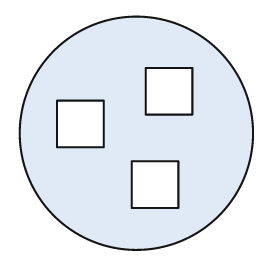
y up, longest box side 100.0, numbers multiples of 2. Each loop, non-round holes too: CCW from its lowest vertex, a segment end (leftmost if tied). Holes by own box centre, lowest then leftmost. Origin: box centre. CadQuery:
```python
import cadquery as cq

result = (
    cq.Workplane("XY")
    .moveTo(0.0, 0.0)
    .circle(50.0)
    .moveTo(-2.0, -32.0)
    .lineTo(18.0, -32.0)
    .lineTo(18.0, -12.0)
    .lineTo(-2.0, -12.0)
    .close()
    .moveTo(-34.0, -6.0)
    .lineTo(-14.0, -6.0)
    .lineTo(-14.0, 14.0)
    .lineTo(-34.0, 14.0)
    .close()
    .moveTo(4.0, 8.0)
    .lineTo(24.0, 8.0)
    .lineTo(24.0, 28.0)
    .lineTo(4.0, 28.0)
    .close()
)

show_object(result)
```